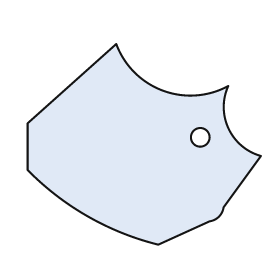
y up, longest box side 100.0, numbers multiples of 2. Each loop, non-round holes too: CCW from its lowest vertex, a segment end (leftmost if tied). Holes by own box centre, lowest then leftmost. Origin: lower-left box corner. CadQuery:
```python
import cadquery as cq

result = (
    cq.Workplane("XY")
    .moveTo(56.0, 0.0)
    .lineTo(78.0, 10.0)
    .threePointArc((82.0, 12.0), (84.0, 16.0))
    .lineTo(100.0, 38.0)
    .threePointArc((86.0, 50.0), (86.0, 68.0))
    .threePointArc((58.0, 66.0), (38.0, 86.0))
    .lineTo(0.0, 52.0)
    .lineTo(0.0, 32.0)
    .threePointArc((26.0, 12.0), (56.0, 0.0))
    .close()
    .moveTo(74.0, 46.0)
    .circle(4.0)
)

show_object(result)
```